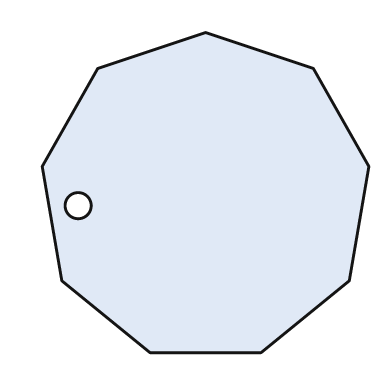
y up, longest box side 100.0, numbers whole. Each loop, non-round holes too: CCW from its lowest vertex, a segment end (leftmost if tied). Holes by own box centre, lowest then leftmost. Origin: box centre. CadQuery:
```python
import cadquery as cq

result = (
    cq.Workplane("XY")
    .moveTo(-17.0, -49.0)
    .lineTo(17.0, -49.0)
    .lineTo(44.0, -27.0)
    .lineTo(50.0, 8.0)
    .lineTo(33.0, 38.0)
    .lineTo(0.0, 49.0)
    .lineTo(-33.0, 38.0)
    .lineTo(-50.0, 8.0)
    .lineTo(-44.0, -27.0)
    .close()
    .moveTo(-39.0, -4.0)
    .circle(4.0)
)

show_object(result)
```